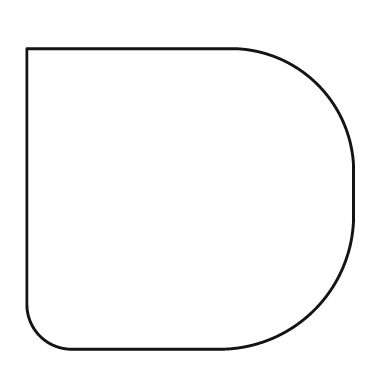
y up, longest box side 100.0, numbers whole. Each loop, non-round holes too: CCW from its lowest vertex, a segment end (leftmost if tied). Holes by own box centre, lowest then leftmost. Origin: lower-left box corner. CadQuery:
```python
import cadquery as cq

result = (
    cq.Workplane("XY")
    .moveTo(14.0, 0.0)
    .lineTo(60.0, 0.0)
    .threePointArc((88.0, 12.0), (100.0, 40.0))
    .lineTo(100.0, 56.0)
    .threePointArc((89.0, 81.0), (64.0, 92.0))
    .lineTo(0.0, 92.0)
    .lineTo(0.0, 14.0)
    .threePointArc((4.0, 4.0), (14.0, 0.0))
    .close()
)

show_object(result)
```